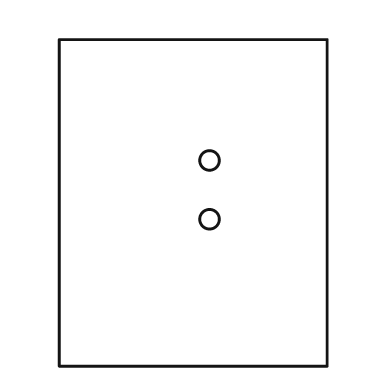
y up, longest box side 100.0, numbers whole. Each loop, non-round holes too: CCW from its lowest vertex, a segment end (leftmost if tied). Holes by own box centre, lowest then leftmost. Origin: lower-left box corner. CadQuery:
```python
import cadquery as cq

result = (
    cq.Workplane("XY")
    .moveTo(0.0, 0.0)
    .lineTo(82.0, 0.0)
    .lineTo(82.0, 100.0)
    .lineTo(0.0, 100.0)
    .close()
    .moveTo(46.0, 45.0)
    .circle(3.0)
    .moveTo(46.0, 63.0)
    .circle(3.0)
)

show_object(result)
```